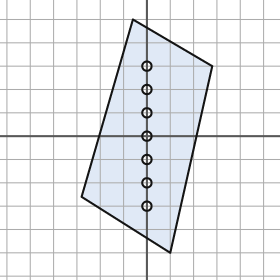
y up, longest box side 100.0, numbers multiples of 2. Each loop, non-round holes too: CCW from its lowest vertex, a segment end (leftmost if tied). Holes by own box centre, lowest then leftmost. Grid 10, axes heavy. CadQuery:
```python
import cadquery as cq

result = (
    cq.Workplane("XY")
    .moveTo(10.0, -50.0)
    .lineTo(28.0, 30.0)
    .lineTo(-6.0, 50.0)
    .lineTo(-28.0, -26.0)
    .close()
    .moveTo(0.0, -30.0)
    .circle(2.0)
    .moveTo(0.0, -20.0)
    .circle(2.0)
    .moveTo(0.0, -10.0)
    .circle(2.0)
    .moveTo(0.0, 0.0)
    .circle(2.0)
    .moveTo(0.0, 10.0)
    .circle(2.0)
    .moveTo(0.0, 20.0)
    .circle(2.0)
    .moveTo(0.0, 30.0)
    .circle(2.0)
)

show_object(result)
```